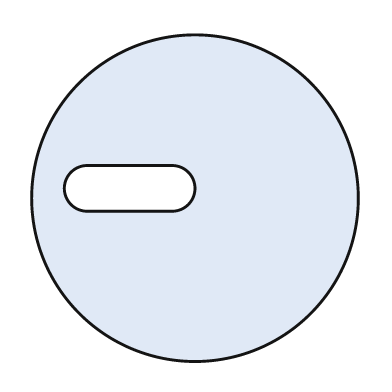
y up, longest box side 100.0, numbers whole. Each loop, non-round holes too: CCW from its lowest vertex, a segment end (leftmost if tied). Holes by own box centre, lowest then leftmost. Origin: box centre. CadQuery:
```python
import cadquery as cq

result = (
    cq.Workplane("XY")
    .moveTo(0.0, 0.0)
    .circle(50.0)
    .moveTo(-33.0, -4.0)
    .lineTo(-7.0, -4.0)
    .threePointArc((0.0, 3.0), (-7.0, 10.0))
    .lineTo(-33.0, 10.0)
    .threePointArc((-40.0, 3.0), (-33.0, -4.0))
    .close()
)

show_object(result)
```